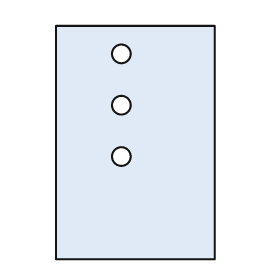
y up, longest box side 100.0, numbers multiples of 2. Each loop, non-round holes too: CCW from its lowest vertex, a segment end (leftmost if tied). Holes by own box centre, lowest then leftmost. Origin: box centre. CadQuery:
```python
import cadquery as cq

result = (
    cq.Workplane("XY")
    .moveTo(-34.0, -50.0)
    .lineTo(34.0, -50.0)
    .lineTo(34.0, 50.0)
    .lineTo(-34.0, 50.0)
    .close()
    .moveTo(-6.0, -6.0)
    .circle(4.0)
    .moveTo(-6.0, 16.0)
    .circle(4.0)
    .moveTo(-6.0, 38.0)
    .circle(4.0)
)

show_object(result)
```